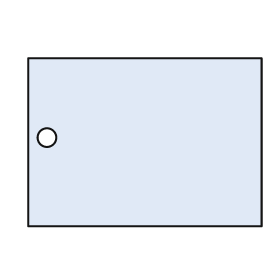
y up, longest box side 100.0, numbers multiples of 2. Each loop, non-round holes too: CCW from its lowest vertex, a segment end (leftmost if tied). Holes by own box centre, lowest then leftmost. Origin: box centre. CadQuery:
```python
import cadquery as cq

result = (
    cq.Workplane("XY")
    .moveTo(-50.0, -36.0)
    .lineTo(50.0, -36.0)
    .lineTo(50.0, 36.0)
    .lineTo(-50.0, 36.0)
    .close()
    .moveTo(-42.0, 2.0)
    .circle(4.0)
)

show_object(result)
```